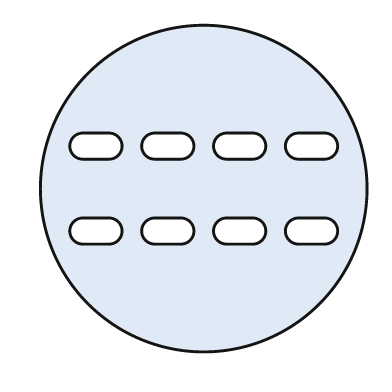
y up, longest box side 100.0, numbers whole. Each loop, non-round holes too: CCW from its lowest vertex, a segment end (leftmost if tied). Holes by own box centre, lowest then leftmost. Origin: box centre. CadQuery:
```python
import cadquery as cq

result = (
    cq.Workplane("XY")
    .moveTo(0.0, 0.0)
    .circle(50.0)
    .moveTo(-37.0, -17.0)
    .lineTo(-29.0, -17.0)
    .threePointArc((-25.0, -13.0), (-29.0, -9.0))
    .lineTo(-37.0, -9.0)
    .threePointArc((-41.0, -13.0), (-37.0, -17.0))
    .close()
    .moveTo(-15.0, -17.0)
    .lineTo(-7.0, -17.0)
    .threePointArc((-3.0, -13.0), (-7.0, -9.0))
    .lineTo(-15.0, -9.0)
    .threePointArc((-19.0, -13.0), (-15.0, -17.0))
    .close()
    .moveTo(7.0, -17.0)
    .lineTo(15.0, -17.0)
    .threePointArc((19.0, -13.0), (15.0, -9.0))
    .lineTo(7.0, -9.0)
    .threePointArc((3.0, -13.0), (7.0, -17.0))
    .close()
    .moveTo(29.0, -17.0)
    .lineTo(37.0, -17.0)
    .threePointArc((41.0, -13.0), (37.0, -9.0))
    .lineTo(29.0, -9.0)
    .threePointArc((25.0, -13.0), (29.0, -17.0))
    .close()
    .moveTo(-37.0, 9.0)
    .lineTo(-29.0, 9.0)
    .threePointArc((-25.0, 13.0), (-29.0, 17.0))
    .lineTo(-37.0, 17.0)
    .threePointArc((-41.0, 13.0), (-37.0, 9.0))
    .close()
    .moveTo(-15.0, 9.0)
    .lineTo(-7.0, 9.0)
    .threePointArc((-3.0, 13.0), (-7.0, 17.0))
    .lineTo(-15.0, 17.0)
    .threePointArc((-19.0, 13.0), (-15.0, 9.0))
    .close()
    .moveTo(7.0, 9.0)
    .lineTo(15.0, 9.0)
    .threePointArc((19.0, 13.0), (15.0, 17.0))
    .lineTo(7.0, 17.0)
    .threePointArc((3.0, 13.0), (7.0, 9.0))
    .close()
    .moveTo(29.0, 9.0)
    .lineTo(37.0, 9.0)
    .threePointArc((41.0, 13.0), (37.0, 17.0))
    .lineTo(29.0, 17.0)
    .threePointArc((25.0, 13.0), (29.0, 9.0))
    .close()
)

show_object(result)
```